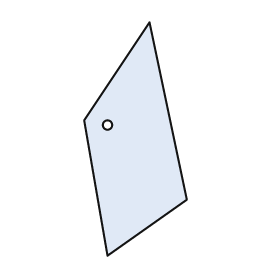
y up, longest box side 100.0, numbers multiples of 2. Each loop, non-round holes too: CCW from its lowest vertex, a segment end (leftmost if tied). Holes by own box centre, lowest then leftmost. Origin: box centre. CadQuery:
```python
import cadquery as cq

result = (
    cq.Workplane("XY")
    .moveTo(-12.0, -50.0)
    .lineTo(22.0, -26.0)
    .lineTo(6.0, 50.0)
    .lineTo(-22.0, 8.0)
    .close()
    .moveTo(-12.0, 6.0)
    .circle(2.0)
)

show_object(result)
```